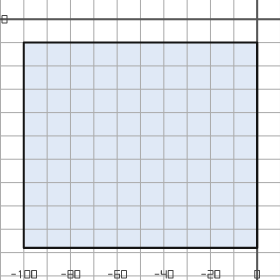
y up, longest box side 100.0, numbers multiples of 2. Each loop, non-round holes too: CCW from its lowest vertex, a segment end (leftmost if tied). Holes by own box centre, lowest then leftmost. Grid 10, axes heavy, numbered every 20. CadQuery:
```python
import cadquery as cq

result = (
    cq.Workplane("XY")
    .moveTo(-100.0, -98.0)
    .lineTo(0.0, -98.0)
    .lineTo(0.0, -10.0)
    .lineTo(-100.0, -10.0)
    .close()
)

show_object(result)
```